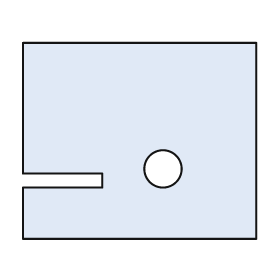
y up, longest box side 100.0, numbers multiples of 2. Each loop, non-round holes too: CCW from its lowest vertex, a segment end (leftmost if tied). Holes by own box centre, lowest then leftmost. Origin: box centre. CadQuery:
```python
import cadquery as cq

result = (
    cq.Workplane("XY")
    .moveTo(-50.0, -42.0)
    .lineTo(50.0, -42.0)
    .lineTo(50.0, 42.0)
    .lineTo(-50.0, 42.0)
    .lineTo(-50.0, -14.0)
    .lineTo(-16.0, -14.0)
    .lineTo(-16.0, -20.0)
    .lineTo(-50.0, -20.0)
    .close()
    .moveTo(10.0, -12.0)
    .circle(8.0)
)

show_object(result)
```